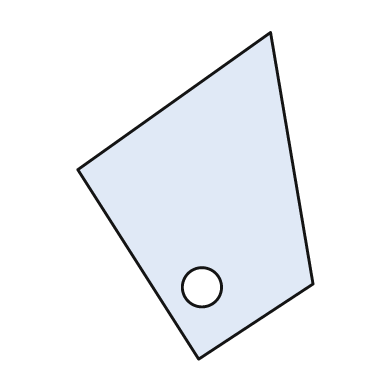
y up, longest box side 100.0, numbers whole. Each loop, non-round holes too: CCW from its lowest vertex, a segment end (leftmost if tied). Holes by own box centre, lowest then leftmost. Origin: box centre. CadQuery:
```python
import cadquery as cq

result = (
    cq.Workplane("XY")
    .moveTo(1.0, -50.0)
    .lineTo(36.0, -27.0)
    .lineTo(23.0, 50.0)
    .lineTo(-36.0, 8.0)
    .close()
    .moveTo(2.0, -28.0)
    .circle(6.0)
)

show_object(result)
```